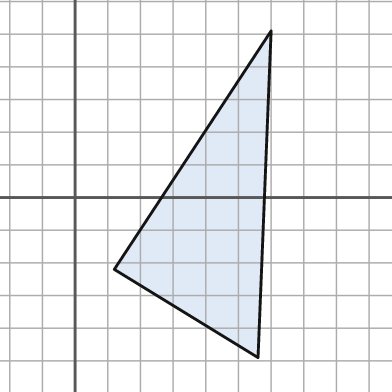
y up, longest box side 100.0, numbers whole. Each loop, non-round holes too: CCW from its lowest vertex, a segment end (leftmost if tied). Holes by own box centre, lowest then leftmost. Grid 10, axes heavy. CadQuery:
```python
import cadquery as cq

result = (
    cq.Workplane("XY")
    .moveTo(56.0, -49.0)
    .lineTo(60.0, 51.0)
    .lineTo(12.0, -22.0)
    .close()
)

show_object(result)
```